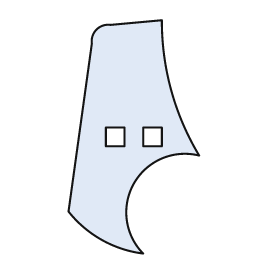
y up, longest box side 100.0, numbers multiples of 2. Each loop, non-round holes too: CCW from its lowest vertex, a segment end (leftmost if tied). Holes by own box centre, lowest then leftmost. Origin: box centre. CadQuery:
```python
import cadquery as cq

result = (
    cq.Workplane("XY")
    .moveTo(4.0, -50.0)
    .threePointArc((0.0, -20.0), (28.0, -8.0))
    .threePointArc((16.0, 20.0), (12.0, 50.0))
    .lineTo(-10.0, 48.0)
    .threePointArc((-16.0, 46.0), (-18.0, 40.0))
    .lineTo(-28.0, -32.0)
    .threePointArc((-14.0, -44.0), (4.0, -50.0))
    .close()
    .moveTo(-12.0, -4.0)
    .lineTo(-4.0, -4.0)
    .lineTo(-4.0, 4.0)
    .lineTo(-12.0, 4.0)
    .close()
    .moveTo(4.0, -4.0)
    .lineTo(12.0, -4.0)
    .lineTo(12.0, 4.0)
    .lineTo(4.0, 4.0)
    .close()
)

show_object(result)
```